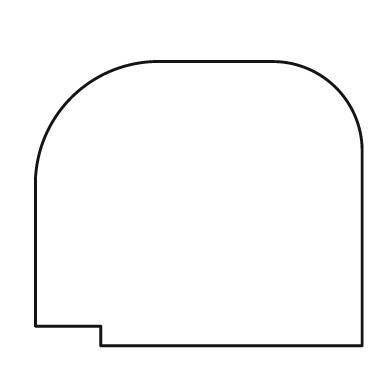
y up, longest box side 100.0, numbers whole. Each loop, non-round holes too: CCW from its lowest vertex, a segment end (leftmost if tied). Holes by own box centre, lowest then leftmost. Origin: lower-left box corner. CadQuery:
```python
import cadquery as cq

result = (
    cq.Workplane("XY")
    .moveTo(20.0, 0.0)
    .lineTo(100.0, 0.0)
    .lineTo(100.0, 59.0)
    .threePointArc((92.0, 79.0), (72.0, 87.0))
    .lineTo(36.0, 87.0)
    .threePointArc((11.0, 76.0), (0.0, 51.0))
    .lineTo(0.0, 6.0)
    .lineTo(20.0, 6.0)
    .close()
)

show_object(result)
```